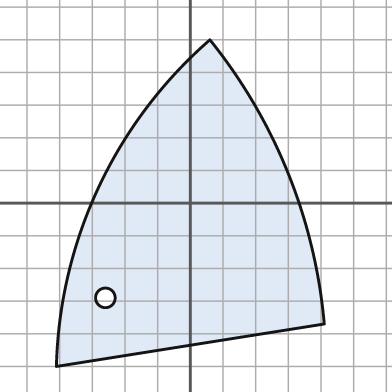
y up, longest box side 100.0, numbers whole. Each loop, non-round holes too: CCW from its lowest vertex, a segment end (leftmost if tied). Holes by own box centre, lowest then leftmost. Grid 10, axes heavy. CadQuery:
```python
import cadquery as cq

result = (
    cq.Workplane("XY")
    .moveTo(-41.0, -50.0)
    .lineTo(41.0, -37.0)
    .threePointArc((30.0, 9.0), (6.0, 50.0))
    .threePointArc((-28.0, 5.0), (-41.0, -50.0))
    .close()
    .moveTo(-26.0, -29.0)
    .circle(3.0)
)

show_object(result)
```